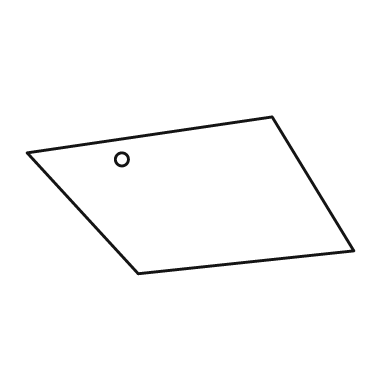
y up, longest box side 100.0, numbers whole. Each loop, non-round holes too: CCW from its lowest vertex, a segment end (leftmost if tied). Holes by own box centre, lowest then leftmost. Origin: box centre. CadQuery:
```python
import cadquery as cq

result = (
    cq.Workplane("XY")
    .moveTo(-16.0, -24.0)
    .lineTo(50.0, -17.0)
    .lineTo(25.0, 24.0)
    .lineTo(-50.0, 13.0)
    .close()
    .moveTo(-21.0, 11.0)
    .circle(2.0)
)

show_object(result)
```